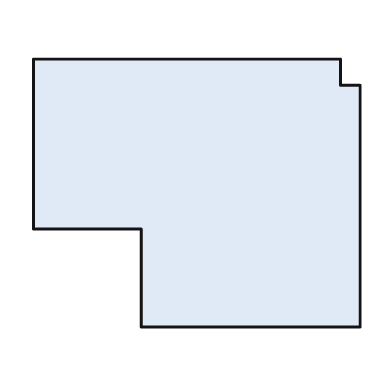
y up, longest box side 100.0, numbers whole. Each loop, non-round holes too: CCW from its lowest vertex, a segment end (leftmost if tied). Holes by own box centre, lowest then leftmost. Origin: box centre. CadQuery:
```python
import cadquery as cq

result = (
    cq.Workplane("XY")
    .moveTo(-17.0, -41.0)
    .lineTo(50.0, -41.0)
    .lineTo(50.0, 33.0)
    .lineTo(44.0, 33.0)
    .lineTo(44.0, 41.0)
    .lineTo(-50.0, 41.0)
    .lineTo(-50.0, -11.0)
    .lineTo(-17.0, -11.0)
    .close()
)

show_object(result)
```